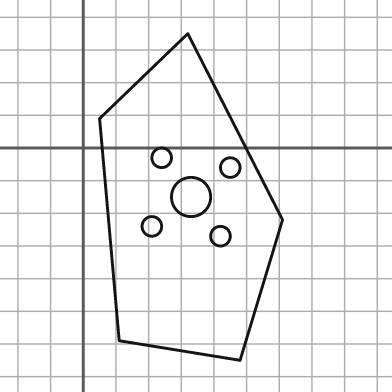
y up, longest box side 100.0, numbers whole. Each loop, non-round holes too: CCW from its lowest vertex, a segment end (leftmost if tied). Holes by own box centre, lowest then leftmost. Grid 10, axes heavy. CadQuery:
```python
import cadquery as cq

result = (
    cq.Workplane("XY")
    .moveTo(48.0, -65.0)
    .lineTo(61.0, -22.0)
    .lineTo(32.0, 35.0)
    .lineTo(5.0, 9.0)
    .lineTo(11.0, -59.0)
    .close()
    .moveTo(42.0, -27.0)
    .circle(3.0)
    .moveTo(21.0, -24.0)
    .circle(3.0)
    .moveTo(33.0, -15.0)
    .circle(6.0)
    .moveTo(45.0, -6.0)
    .circle(3.0)
    .moveTo(24.0, -3.0)
    .circle(3.0)
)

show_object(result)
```